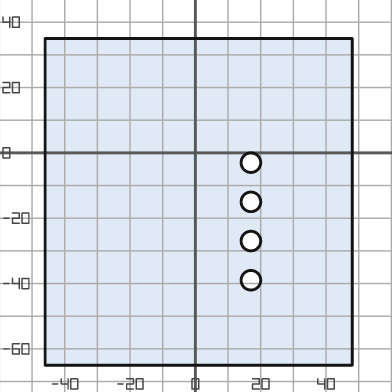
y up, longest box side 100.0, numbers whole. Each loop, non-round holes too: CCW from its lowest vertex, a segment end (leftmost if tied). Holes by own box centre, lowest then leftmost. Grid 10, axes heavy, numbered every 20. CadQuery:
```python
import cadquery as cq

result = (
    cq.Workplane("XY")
    .moveTo(-46.0, -65.0)
    .lineTo(48.0, -65.0)
    .lineTo(48.0, 35.0)
    .lineTo(-46.0, 35.0)
    .close()
    .moveTo(17.0, -39.0)
    .circle(3.0)
    .moveTo(17.0, -27.0)
    .circle(3.0)
    .moveTo(17.0, -15.0)
    .circle(3.0)
    .moveTo(17.0, -3.0)
    .circle(3.0)
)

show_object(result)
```